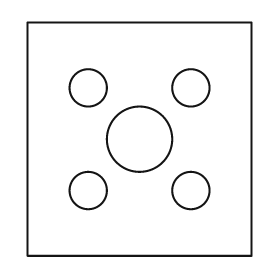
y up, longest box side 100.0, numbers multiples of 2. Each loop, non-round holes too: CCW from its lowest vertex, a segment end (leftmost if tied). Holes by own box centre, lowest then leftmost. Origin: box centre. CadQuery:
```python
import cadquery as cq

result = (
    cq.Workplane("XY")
    .moveTo(-48.0, -50.0)
    .lineTo(48.0, -50.0)
    .lineTo(48.0, 50.0)
    .lineTo(-48.0, 50.0)
    .close()
    .moveTo(-22.0, -22.0)
    .circle(8.0)
    .moveTo(22.0, -22.0)
    .circle(8.0)
    .moveTo(0.0, 0.0)
    .circle(14.0)
    .moveTo(-22.0, 22.0)
    .circle(8.0)
    .moveTo(22.0, 22.0)
    .circle(8.0)
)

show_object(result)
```